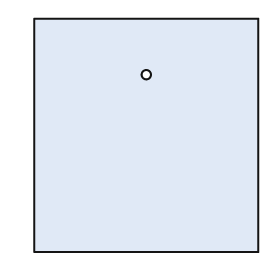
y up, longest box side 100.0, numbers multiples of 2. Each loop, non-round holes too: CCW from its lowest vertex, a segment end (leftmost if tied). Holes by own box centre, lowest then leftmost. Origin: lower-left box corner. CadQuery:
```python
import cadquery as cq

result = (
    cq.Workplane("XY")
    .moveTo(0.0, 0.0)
    .lineTo(96.0, 0.0)
    .lineTo(96.0, 100.0)
    .lineTo(0.0, 100.0)
    .close()
    .moveTo(48.0, 76.0)
    .circle(2.0)
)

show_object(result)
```